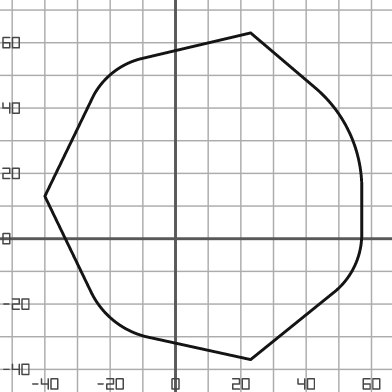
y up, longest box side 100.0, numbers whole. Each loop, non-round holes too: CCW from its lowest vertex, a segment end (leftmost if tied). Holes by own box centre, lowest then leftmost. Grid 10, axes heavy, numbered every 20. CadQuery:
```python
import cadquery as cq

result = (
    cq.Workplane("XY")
    .moveTo(23.0, -37.0)
    .lineTo(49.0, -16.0)
    .threePointArc((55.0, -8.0), (57.0, 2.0))
    .lineTo(57.0, 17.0)
    .threePointArc((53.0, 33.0), (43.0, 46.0))
    .lineTo(23.0, 63.0)
    .lineTo(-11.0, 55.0)
    .threePointArc((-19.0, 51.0), (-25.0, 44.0))
    .lineTo(-40.0, 13.0)
    .lineTo(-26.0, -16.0)
    .threePointArc((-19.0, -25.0), (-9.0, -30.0))
    .close()
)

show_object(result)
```